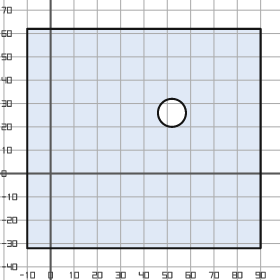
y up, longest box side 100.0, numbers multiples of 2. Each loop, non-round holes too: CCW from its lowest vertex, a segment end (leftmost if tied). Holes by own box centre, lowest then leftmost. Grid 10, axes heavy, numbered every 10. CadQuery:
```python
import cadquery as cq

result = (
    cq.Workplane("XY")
    .moveTo(-10.0, -32.0)
    .lineTo(90.0, -32.0)
    .lineTo(90.0, 62.0)
    .lineTo(-10.0, 62.0)
    .close()
    .moveTo(52.0, 26.0)
    .circle(6.0)
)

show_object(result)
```